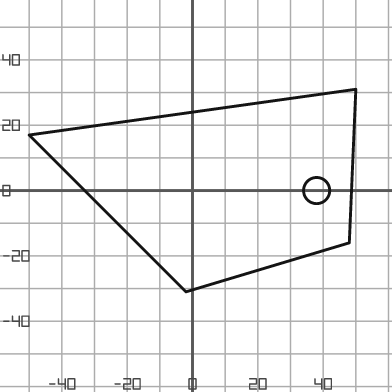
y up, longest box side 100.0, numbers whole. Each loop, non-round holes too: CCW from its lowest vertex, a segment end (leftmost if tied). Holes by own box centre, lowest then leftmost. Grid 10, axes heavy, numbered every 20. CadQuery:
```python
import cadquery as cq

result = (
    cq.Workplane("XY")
    .moveTo(-2.0, -31.0)
    .lineTo(48.0, -16.0)
    .lineTo(50.0, 31.0)
    .lineTo(-50.0, 17.0)
    .close()
    .moveTo(38.0, 0.0)
    .circle(4.0)
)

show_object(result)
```